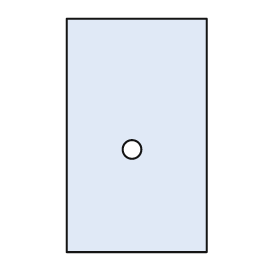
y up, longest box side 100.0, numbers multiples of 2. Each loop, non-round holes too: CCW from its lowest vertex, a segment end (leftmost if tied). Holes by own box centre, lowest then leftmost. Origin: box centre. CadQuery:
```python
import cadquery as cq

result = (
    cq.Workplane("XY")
    .moveTo(-30.0, -50.0)
    .lineTo(30.0, -50.0)
    .lineTo(30.0, 50.0)
    .lineTo(-30.0, 50.0)
    .close()
    .moveTo(-2.0, -6.0)
    .circle(4.0)
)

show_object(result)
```